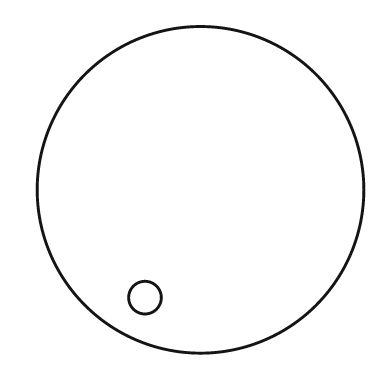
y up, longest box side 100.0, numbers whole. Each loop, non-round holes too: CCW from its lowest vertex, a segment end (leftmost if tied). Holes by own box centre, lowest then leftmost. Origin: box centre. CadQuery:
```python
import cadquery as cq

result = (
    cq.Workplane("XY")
    .moveTo(0.0, 0.0)
    .circle(50.0)
    .moveTo(-17.0, -33.0)
    .circle(5.0)
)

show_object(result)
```